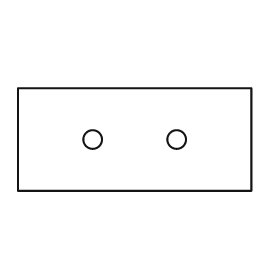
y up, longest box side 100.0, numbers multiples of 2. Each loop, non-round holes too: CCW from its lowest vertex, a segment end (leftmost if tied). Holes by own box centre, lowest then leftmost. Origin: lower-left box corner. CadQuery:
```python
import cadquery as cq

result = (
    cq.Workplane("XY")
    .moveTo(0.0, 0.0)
    .lineTo(100.0, 0.0)
    .lineTo(100.0, 44.0)
    .lineTo(0.0, 44.0)
    .close()
    .moveTo(32.0, 22.0)
    .circle(4.0)
    .moveTo(68.0, 22.0)
    .circle(4.0)
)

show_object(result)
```